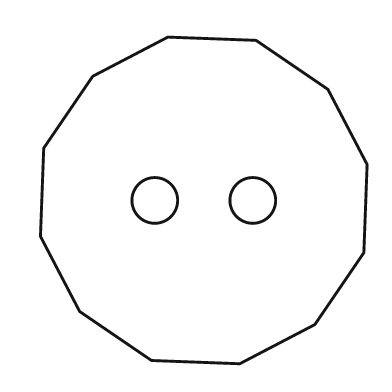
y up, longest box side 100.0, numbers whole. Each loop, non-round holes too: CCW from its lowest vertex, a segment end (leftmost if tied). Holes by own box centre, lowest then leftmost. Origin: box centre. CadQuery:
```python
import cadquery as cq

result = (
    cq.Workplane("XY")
    .moveTo(11.0, -50.0)
    .lineTo(34.0, -38.0)
    .lineTo(49.0, -16.0)
    .lineTo(50.0, 11.0)
    .lineTo(38.0, 34.0)
    .lineTo(16.0, 49.0)
    .lineTo(-11.0, 50.0)
    .lineTo(-34.0, 38.0)
    .lineTo(-49.0, 16.0)
    .lineTo(-50.0, -11.0)
    .lineTo(-38.0, -34.0)
    .lineTo(-16.0, -49.0)
    .close()
    .moveTo(-15.0, 0.0)
    .circle(7.0)
    .moveTo(15.0, 0.0)
    .circle(7.0)
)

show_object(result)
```